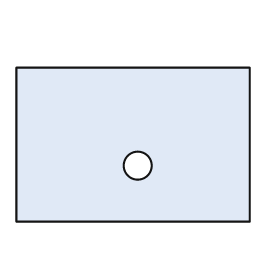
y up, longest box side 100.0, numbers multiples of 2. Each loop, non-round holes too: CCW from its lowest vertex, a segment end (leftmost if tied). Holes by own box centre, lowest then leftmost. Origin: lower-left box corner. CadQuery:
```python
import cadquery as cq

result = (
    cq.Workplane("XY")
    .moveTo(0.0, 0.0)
    .lineTo(100.0, 0.0)
    .lineTo(100.0, 66.0)
    .lineTo(0.0, 66.0)
    .close()
    .moveTo(52.0, 24.0)
    .circle(6.0)
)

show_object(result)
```